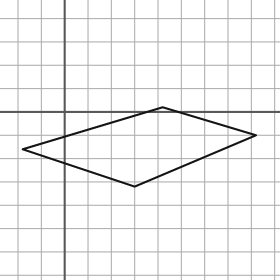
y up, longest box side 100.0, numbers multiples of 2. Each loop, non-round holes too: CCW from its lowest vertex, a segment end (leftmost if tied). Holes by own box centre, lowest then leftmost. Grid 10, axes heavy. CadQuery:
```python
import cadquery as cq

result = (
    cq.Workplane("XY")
    .moveTo(30.0, -32.0)
    .lineTo(82.0, -10.0)
    .lineTo(42.0, 2.0)
    .lineTo(-18.0, -16.0)
    .close()
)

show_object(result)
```